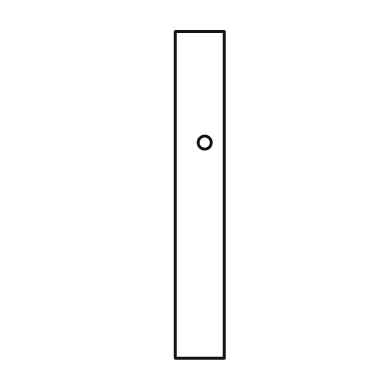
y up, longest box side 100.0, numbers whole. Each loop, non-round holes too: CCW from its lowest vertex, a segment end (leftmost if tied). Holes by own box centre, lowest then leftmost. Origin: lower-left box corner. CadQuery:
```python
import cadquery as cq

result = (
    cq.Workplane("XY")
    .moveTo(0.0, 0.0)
    .lineTo(15.0, 0.0)
    .lineTo(15.0, 100.0)
    .lineTo(0.0, 100.0)
    .close()
    .moveTo(9.0, 66.0)
    .circle(2.0)
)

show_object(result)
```